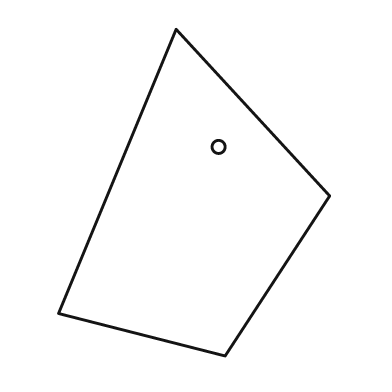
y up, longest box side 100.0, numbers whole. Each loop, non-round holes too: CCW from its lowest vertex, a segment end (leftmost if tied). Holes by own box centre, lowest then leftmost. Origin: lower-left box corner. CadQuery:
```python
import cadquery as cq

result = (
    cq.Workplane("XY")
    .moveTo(51.0, 0.0)
    .lineTo(83.0, 49.0)
    .lineTo(36.0, 100.0)
    .lineTo(0.0, 13.0)
    .close()
    .moveTo(49.0, 64.0)
    .circle(2.0)
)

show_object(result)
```